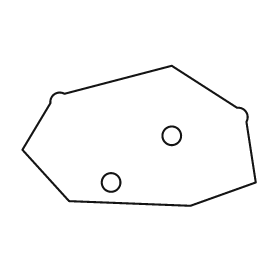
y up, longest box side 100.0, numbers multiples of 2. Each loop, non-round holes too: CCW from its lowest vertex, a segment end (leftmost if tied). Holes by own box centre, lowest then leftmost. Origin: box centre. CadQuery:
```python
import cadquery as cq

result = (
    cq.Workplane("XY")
    .moveTo(22.0, -30.0)
    .lineTo(50.0, -20.0)
    .lineTo(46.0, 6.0)
    .threePointArc((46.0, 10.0), (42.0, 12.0))
    .lineTo(14.0, 30.0)
    .lineTo(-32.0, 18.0)
    .threePointArc((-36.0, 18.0), (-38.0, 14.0))
    .lineTo(-50.0, -6.0)
    .lineTo(-30.0, -28.0)
    .close()
    .moveTo(-12.0, -20.0)
    .circle(4.0)
    .moveTo(14.0, 0.0)
    .circle(4.0)
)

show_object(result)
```